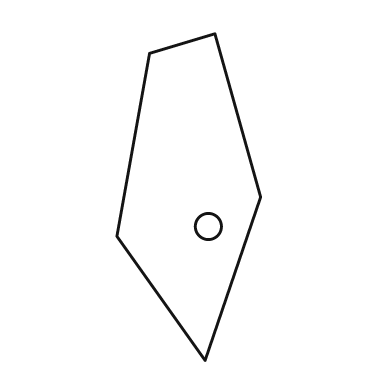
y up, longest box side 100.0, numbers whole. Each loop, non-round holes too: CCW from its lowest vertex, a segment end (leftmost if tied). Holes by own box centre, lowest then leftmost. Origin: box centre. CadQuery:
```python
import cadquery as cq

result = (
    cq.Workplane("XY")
    .moveTo(5.0, -50.0)
    .lineTo(22.0, 0.0)
    .lineTo(8.0, 50.0)
    .lineTo(-12.0, 44.0)
    .lineTo(-22.0, -12.0)
    .close()
    .moveTo(6.0, -9.0)
    .circle(4.0)
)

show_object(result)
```